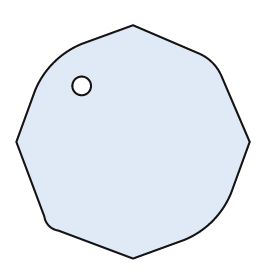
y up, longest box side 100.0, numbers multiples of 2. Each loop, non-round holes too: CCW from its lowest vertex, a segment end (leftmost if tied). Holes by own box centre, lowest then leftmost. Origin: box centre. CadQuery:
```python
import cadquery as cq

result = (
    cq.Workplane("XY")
    .moveTo(0.0, -50.0)
    .lineTo(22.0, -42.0)
    .threePointArc((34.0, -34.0), (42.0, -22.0))
    .lineTo(50.0, 0.0)
    .lineTo(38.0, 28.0)
    .threePointArc((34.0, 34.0), (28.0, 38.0))
    .lineTo(0.0, 50.0)
    .lineTo(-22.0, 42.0)
    .threePointArc((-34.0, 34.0), (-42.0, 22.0))
    .lineTo(-50.0, 0.0)
    .lineTo(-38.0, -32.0)
    .threePointArc((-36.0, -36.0), (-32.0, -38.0))
    .close()
    .moveTo(-22.0, 24.0)
    .circle(4.0)
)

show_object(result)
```